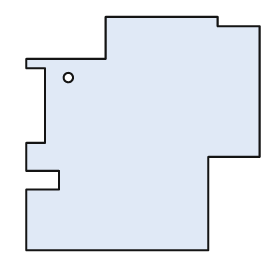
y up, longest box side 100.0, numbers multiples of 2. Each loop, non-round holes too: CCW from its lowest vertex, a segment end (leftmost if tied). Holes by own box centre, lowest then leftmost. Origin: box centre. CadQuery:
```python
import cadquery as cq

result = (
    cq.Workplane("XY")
    .moveTo(-50.0, -50.0)
    .lineTo(28.0, -50.0)
    .lineTo(28.0, -10.0)
    .lineTo(50.0, -10.0)
    .lineTo(50.0, 46.0)
    .lineTo(32.0, 46.0)
    .lineTo(32.0, 50.0)
    .lineTo(-16.0, 50.0)
    .lineTo(-16.0, 32.0)
    .lineTo(-50.0, 32.0)
    .lineTo(-50.0, 28.0)
    .lineTo(-42.0, 28.0)
    .lineTo(-42.0, -4.0)
    .lineTo(-50.0, -4.0)
    .lineTo(-50.0, -16.0)
    .lineTo(-36.0, -16.0)
    .lineTo(-36.0, -24.0)
    .lineTo(-50.0, -24.0)
    .close()
    .moveTo(-32.0, 24.0)
    .circle(2.0)
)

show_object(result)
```